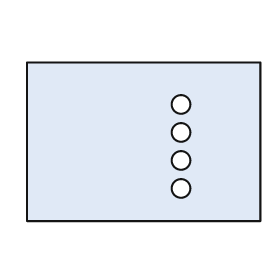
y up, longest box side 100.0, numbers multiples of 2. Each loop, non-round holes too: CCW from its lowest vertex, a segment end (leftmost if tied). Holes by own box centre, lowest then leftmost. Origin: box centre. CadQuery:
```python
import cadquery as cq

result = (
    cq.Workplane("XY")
    .moveTo(-50.0, -34.0)
    .lineTo(50.0, -34.0)
    .lineTo(50.0, 34.0)
    .lineTo(-50.0, 34.0)
    .close()
    .moveTo(16.0, -20.0)
    .circle(4.0)
    .moveTo(16.0, -8.0)
    .circle(4.0)
    .moveTo(16.0, 4.0)
    .circle(4.0)
    .moveTo(16.0, 16.0)
    .circle(4.0)
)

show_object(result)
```